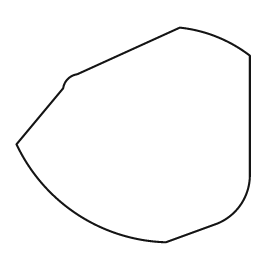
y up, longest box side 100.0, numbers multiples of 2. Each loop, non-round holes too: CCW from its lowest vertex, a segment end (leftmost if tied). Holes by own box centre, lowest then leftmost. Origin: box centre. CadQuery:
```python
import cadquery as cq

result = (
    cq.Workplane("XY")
    .moveTo(14.0, -46.0)
    .lineTo(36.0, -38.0)
    .threePointArc((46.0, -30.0), (50.0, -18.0))
    .lineTo(50.0, 34.0)
    .threePointArc((36.0, 42.0), (20.0, 46.0))
    .lineTo(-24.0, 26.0)
    .threePointArc((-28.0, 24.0), (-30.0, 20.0))
    .lineTo(-50.0, -4.0)
    .threePointArc((-24.0, -34.0), (14.0, -46.0))
    .close()
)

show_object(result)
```